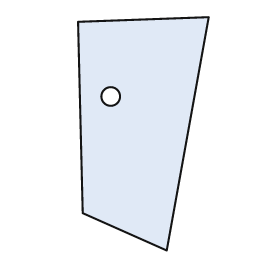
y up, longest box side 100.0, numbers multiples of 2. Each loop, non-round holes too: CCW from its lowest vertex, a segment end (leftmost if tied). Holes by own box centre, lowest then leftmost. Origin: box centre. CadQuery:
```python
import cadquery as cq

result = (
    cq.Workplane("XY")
    .moveTo(10.0, -50.0)
    .lineTo(28.0, 50.0)
    .lineTo(-28.0, 48.0)
    .lineTo(-26.0, -34.0)
    .close()
    .moveTo(-14.0, 16.0)
    .circle(4.0)
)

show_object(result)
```